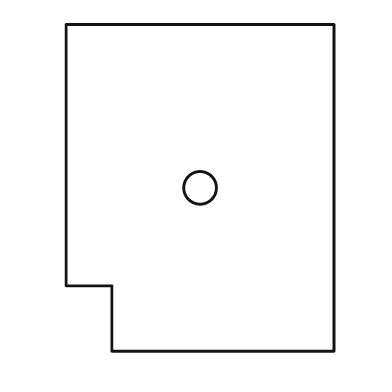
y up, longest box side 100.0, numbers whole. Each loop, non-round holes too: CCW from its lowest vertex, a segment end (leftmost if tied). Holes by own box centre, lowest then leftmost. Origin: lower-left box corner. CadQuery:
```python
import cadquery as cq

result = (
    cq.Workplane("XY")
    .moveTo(14.0, 0.0)
    .lineTo(82.0, 0.0)
    .lineTo(82.0, 100.0)
    .lineTo(0.0, 100.0)
    .lineTo(0.0, 20.0)
    .lineTo(14.0, 20.0)
    .close()
    .moveTo(41.0, 50.0)
    .circle(5.0)
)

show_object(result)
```